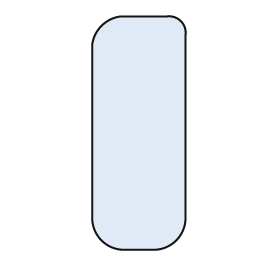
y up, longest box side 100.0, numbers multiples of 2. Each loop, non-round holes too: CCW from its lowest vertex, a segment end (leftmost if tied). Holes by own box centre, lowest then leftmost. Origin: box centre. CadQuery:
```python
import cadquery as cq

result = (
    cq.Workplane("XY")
    .moveTo(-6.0, -50.0)
    .lineTo(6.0, -50.0)
    .threePointArc((16.0, -46.0), (20.0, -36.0))
    .lineTo(20.0, 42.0)
    .threePointArc((18.0, 48.0), (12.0, 50.0))
    .lineTo(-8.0, 50.0)
    .threePointArc((-16.0, 46.0), (-20.0, 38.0))
    .lineTo(-20.0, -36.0)
    .threePointArc((-16.0, -46.0), (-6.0, -50.0))
    .close()
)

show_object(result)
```